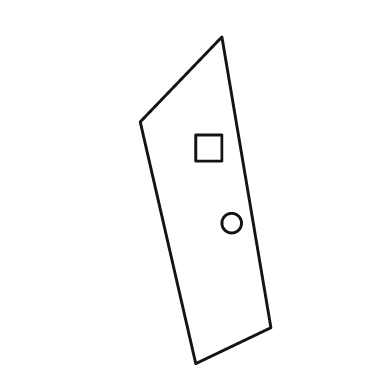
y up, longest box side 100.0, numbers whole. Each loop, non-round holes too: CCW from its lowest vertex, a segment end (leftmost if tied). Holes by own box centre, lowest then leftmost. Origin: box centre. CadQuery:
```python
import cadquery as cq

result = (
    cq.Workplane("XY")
    .moveTo(-3.0, -50.0)
    .lineTo(20.0, -39.0)
    .lineTo(5.0, 50.0)
    .lineTo(-20.0, 24.0)
    .close()
    .moveTo(8.0, -7.0)
    .circle(3.0)
    .moveTo(-3.0, 12.0)
    .lineTo(5.0, 12.0)
    .lineTo(5.0, 20.0)
    .lineTo(-3.0, 20.0)
    .close()
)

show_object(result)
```